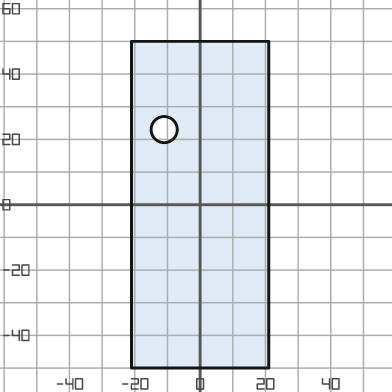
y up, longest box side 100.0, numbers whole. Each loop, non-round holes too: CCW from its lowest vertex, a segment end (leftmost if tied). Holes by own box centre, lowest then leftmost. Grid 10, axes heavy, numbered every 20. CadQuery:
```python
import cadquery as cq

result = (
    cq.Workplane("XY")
    .moveTo(-21.0, -50.0)
    .lineTo(21.0, -50.0)
    .lineTo(21.0, 50.0)
    .lineTo(-21.0, 50.0)
    .close()
    .moveTo(-11.0, 23.0)
    .circle(4.0)
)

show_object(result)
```